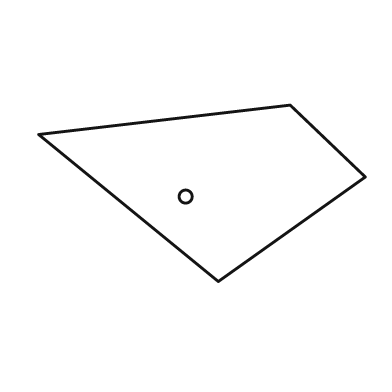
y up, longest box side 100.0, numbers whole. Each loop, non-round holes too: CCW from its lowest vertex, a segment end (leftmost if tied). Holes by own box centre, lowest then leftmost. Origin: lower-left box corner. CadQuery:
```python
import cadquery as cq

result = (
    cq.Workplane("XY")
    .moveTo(55.0, 0.0)
    .lineTo(100.0, 32.0)
    .lineTo(77.0, 54.0)
    .lineTo(0.0, 45.0)
    .close()
    .moveTo(45.0, 26.0)
    .circle(2.0)
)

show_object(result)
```